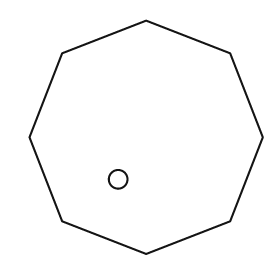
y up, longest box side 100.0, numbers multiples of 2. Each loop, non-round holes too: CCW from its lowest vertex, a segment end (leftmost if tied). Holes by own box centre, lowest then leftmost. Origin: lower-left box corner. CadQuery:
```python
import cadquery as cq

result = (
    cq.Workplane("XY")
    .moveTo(50.0, 0.0)
    .lineTo(86.0, 14.0)
    .lineTo(100.0, 50.0)
    .lineTo(86.0, 86.0)
    .lineTo(50.0, 100.0)
    .lineTo(14.0, 86.0)
    .lineTo(0.0, 50.0)
    .lineTo(14.0, 14.0)
    .close()
    .moveTo(38.0, 32.0)
    .circle(4.0)
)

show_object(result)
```